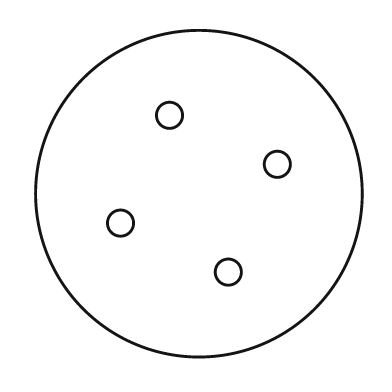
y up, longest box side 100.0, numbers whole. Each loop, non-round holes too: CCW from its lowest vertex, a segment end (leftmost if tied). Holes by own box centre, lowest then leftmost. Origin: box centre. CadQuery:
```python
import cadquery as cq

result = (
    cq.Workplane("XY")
    .moveTo(0.0, 0.0)
    .circle(50.0)
    .moveTo(9.0, -24.0)
    .circle(4.0)
    .moveTo(-24.0, -9.0)
    .circle(4.0)
    .moveTo(24.0, 9.0)
    .circle(4.0)
    .moveTo(-9.0, 24.0)
    .circle(4.0)
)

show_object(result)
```